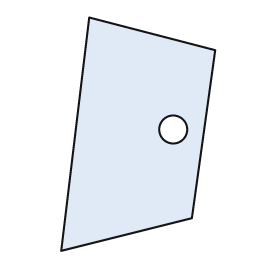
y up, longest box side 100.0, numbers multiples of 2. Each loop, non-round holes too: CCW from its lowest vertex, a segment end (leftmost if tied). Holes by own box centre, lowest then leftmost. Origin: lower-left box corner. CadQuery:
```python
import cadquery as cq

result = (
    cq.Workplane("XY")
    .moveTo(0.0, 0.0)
    .lineTo(56.0, 14.0)
    .lineTo(66.0, 86.0)
    .lineTo(12.0, 100.0)
    .close()
    .moveTo(48.0, 52.0)
    .circle(6.0)
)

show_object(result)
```